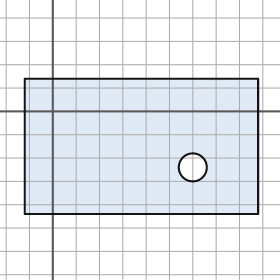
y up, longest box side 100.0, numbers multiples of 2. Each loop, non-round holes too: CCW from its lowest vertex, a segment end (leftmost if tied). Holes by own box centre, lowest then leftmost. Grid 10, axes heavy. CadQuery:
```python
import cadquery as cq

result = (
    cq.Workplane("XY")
    .moveTo(-12.0, -44.0)
    .lineTo(88.0, -44.0)
    .lineTo(88.0, 14.0)
    .lineTo(-12.0, 14.0)
    .close()
    .moveTo(60.0, -24.0)
    .circle(6.0)
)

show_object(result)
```